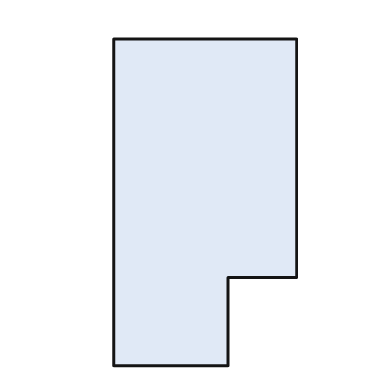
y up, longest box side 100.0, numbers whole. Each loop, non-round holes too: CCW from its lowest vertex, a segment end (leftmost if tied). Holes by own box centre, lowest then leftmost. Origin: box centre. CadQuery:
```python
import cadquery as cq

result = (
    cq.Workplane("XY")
    .moveTo(-28.0, -50.0)
    .lineTo(7.0, -50.0)
    .lineTo(7.0, -23.0)
    .lineTo(28.0, -23.0)
    .lineTo(28.0, 50.0)
    .lineTo(-28.0, 50.0)
    .close()
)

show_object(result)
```